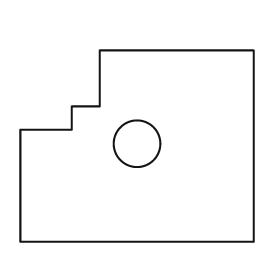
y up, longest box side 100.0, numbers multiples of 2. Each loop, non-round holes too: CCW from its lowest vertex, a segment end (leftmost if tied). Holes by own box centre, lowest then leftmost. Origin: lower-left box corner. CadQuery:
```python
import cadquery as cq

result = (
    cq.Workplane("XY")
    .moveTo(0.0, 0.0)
    .lineTo(100.0, 0.0)
    .lineTo(100.0, 82.0)
    .lineTo(34.0, 82.0)
    .lineTo(34.0, 58.0)
    .lineTo(22.0, 58.0)
    .lineTo(22.0, 48.0)
    .lineTo(0.0, 48.0)
    .close()
    .moveTo(50.0, 42.0)
    .circle(10.0)
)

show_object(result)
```